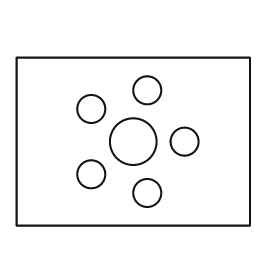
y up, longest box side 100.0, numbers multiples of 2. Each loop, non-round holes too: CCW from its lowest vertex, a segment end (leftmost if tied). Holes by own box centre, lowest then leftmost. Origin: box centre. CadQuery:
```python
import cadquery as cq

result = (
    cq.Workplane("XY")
    .moveTo(-50.0, -36.0)
    .lineTo(50.0, -36.0)
    .lineTo(50.0, 36.0)
    .lineTo(-50.0, 36.0)
    .close()
    .moveTo(6.0, -22.0)
    .circle(6.0)
    .moveTo(-18.0, -14.0)
    .circle(6.0)
    .moveTo(0.0, 0.0)
    .circle(10.0)
    .moveTo(22.0, 0.0)
    .circle(6.0)
    .moveTo(-18.0, 14.0)
    .circle(6.0)
    .moveTo(6.0, 22.0)
    .circle(6.0)
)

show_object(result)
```